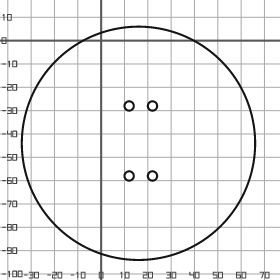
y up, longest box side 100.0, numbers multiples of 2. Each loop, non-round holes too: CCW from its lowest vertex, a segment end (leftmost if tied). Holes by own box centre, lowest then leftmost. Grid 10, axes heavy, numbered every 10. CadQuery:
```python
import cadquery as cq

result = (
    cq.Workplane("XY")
    .moveTo(16.0, -44.0)
    .circle(50.0)
    .moveTo(12.0, -58.0)
    .circle(2.0)
    .moveTo(22.0, -58.0)
    .circle(2.0)
    .moveTo(12.0, -28.0)
    .circle(2.0)
    .moveTo(22.0, -28.0)
    .circle(2.0)
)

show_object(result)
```